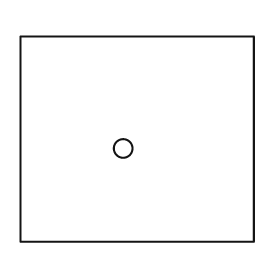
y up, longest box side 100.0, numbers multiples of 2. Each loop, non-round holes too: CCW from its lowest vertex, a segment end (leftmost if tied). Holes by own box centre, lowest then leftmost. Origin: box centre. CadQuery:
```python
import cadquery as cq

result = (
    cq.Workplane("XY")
    .moveTo(-50.0, -44.0)
    .lineTo(50.0, -44.0)
    .lineTo(50.0, 44.0)
    .lineTo(-50.0, 44.0)
    .close()
    .moveTo(-6.0, -4.0)
    .circle(4.0)
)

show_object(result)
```